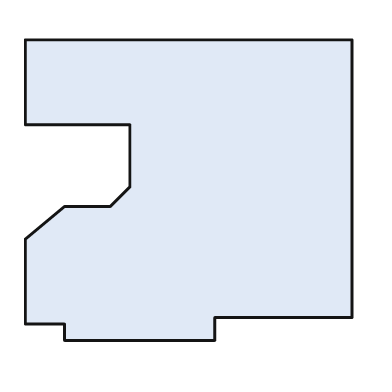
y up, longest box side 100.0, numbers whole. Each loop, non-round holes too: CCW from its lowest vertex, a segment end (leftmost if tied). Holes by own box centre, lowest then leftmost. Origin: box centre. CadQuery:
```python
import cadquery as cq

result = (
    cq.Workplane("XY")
    .moveTo(-38.0, -46.0)
    .lineTo(8.0, -46.0)
    .lineTo(8.0, -39.0)
    .lineTo(50.0, -39.0)
    .lineTo(50.0, 46.0)
    .lineTo(-50.0, 46.0)
    .lineTo(-50.0, 20.0)
    .lineTo(-18.0, 20.0)
    .lineTo(-18.0, 1.0)
    .lineTo(-24.0, -5.0)
    .lineTo(-38.0, -5.0)
    .lineTo(-50.0, -15.0)
    .lineTo(-50.0, -41.0)
    .lineTo(-38.0, -41.0)
    .close()
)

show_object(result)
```